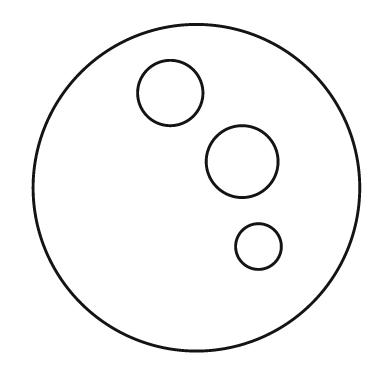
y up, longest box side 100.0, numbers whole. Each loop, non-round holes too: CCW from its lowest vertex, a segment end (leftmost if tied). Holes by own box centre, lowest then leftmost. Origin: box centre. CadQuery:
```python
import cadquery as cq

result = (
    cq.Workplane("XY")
    .moveTo(0.0, 0.0)
    .circle(50.0)
    .moveTo(19.0, -18.0)
    .circle(7.0)
    .moveTo(14.0, 8.0)
    .circle(11.0)
    .moveTo(-8.0, 29.0)
    .circle(10.0)
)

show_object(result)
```